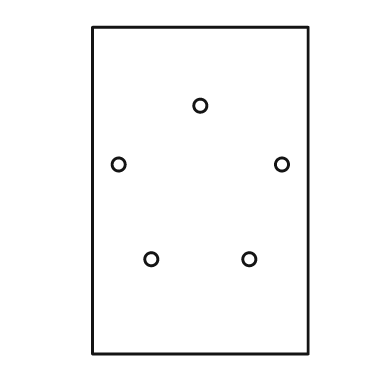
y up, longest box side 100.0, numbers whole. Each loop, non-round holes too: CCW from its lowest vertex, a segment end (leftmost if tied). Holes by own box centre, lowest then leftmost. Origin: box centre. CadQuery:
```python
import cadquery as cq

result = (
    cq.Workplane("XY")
    .moveTo(-33.0, -50.0)
    .lineTo(33.0, -50.0)
    .lineTo(33.0, 50.0)
    .lineTo(-33.0, 50.0)
    .close()
    .moveTo(-15.0, -21.0)
    .circle(2.0)
    .moveTo(15.0, -21.0)
    .circle(2.0)
    .moveTo(-25.0, 8.0)
    .circle(2.0)
    .moveTo(25.0, 8.0)
    .circle(2.0)
    .moveTo(0.0, 26.0)
    .circle(2.0)
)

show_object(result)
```